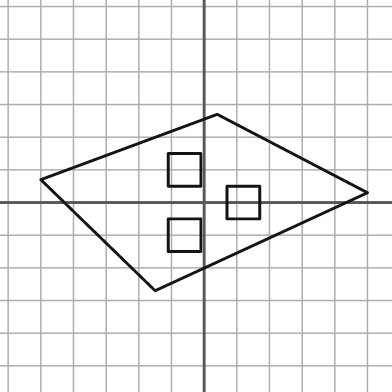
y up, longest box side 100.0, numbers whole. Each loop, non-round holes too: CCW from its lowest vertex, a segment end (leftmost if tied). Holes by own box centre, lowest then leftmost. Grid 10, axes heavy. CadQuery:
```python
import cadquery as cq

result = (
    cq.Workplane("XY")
    .moveTo(-15.0, -27.0)
    .lineTo(50.0, 3.0)
    .lineTo(4.0, 27.0)
    .lineTo(-50.0, 7.0)
    .close()
    .moveTo(-11.0, -15.0)
    .lineTo(-1.0, -15.0)
    .lineTo(-1.0, -5.0)
    .lineTo(-11.0, -5.0)
    .close()
    .moveTo(7.0, -5.0)
    .lineTo(17.0, -5.0)
    .lineTo(17.0, 5.0)
    .lineTo(7.0, 5.0)
    .close()
    .moveTo(-11.0, 5.0)
    .lineTo(-1.0, 5.0)
    .lineTo(-1.0, 15.0)
    .lineTo(-11.0, 15.0)
    .close()
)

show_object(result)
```